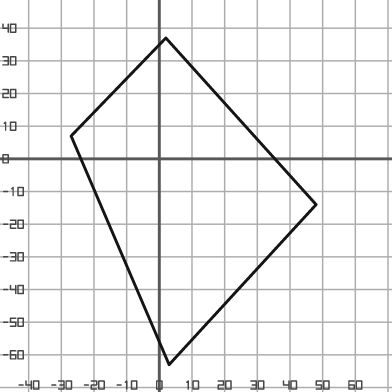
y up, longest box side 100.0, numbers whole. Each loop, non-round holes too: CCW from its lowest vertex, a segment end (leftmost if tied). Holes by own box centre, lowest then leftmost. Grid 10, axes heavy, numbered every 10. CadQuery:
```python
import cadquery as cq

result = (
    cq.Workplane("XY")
    .moveTo(3.0, -63.0)
    .lineTo(48.0, -14.0)
    .lineTo(2.0, 37.0)
    .lineTo(-27.0, 7.0)
    .close()
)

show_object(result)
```